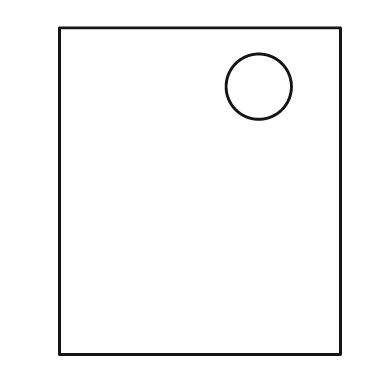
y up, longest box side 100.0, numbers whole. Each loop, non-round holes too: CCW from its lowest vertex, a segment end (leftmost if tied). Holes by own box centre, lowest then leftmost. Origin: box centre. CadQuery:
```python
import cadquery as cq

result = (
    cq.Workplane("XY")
    .moveTo(-43.0, -50.0)
    .lineTo(43.0, -50.0)
    .lineTo(43.0, 50.0)
    .lineTo(-43.0, 50.0)
    .close()
    .moveTo(18.0, 32.0)
    .circle(10.0)
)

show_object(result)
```